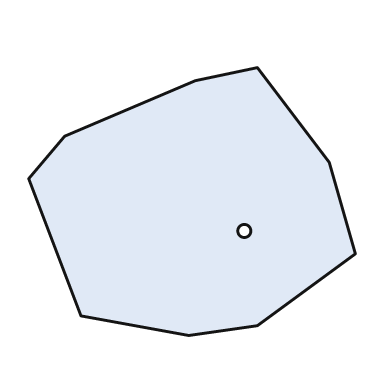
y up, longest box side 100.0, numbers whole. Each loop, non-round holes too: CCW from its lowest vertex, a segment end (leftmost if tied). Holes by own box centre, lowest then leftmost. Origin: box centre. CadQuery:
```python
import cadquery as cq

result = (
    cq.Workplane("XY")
    .moveTo(-1.0, -41.0)
    .lineTo(20.0, -38.0)
    .lineTo(50.0, -16.0)
    .lineTo(42.0, 12.0)
    .lineTo(20.0, 41.0)
    .lineTo(1.0, 37.0)
    .lineTo(-39.0, 20.0)
    .lineTo(-50.0, 7.0)
    .lineTo(-34.0, -35.0)
    .close()
    .moveTo(16.0, -9.0)
    .circle(2.0)
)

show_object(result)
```